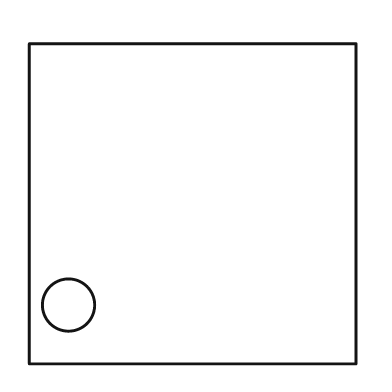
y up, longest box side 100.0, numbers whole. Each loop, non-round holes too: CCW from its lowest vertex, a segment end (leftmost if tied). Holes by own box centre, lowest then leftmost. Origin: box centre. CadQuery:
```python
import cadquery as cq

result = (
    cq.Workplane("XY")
    .moveTo(-50.0, -49.0)
    .lineTo(50.0, -49.0)
    .lineTo(50.0, 49.0)
    .lineTo(-50.0, 49.0)
    .close()
    .moveTo(-38.0, -31.0)
    .circle(8.0)
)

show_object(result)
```